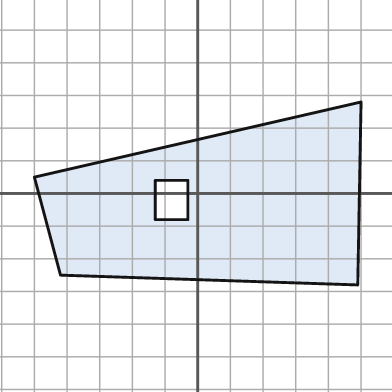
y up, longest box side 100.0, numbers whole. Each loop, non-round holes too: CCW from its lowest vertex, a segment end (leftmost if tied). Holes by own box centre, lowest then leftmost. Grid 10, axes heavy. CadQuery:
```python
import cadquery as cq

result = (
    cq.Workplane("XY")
    .moveTo(49.0, -28.0)
    .lineTo(50.0, 28.0)
    .lineTo(-50.0, 5.0)
    .lineTo(-42.0, -25.0)
    .close()
    .moveTo(-13.0, -8.0)
    .lineTo(-3.0, -8.0)
    .lineTo(-3.0, 4.0)
    .lineTo(-13.0, 4.0)
    .close()
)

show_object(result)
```